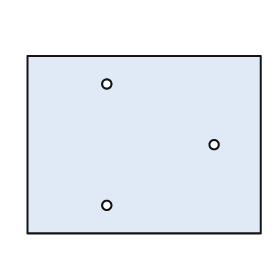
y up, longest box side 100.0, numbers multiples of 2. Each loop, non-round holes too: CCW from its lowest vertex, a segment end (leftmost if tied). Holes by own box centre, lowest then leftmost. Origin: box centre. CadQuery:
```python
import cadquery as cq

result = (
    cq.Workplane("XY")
    .moveTo(-50.0, -38.0)
    .lineTo(50.0, -38.0)
    .lineTo(50.0, 38.0)
    .lineTo(-50.0, 38.0)
    .close()
    .moveTo(-16.0, -26.0)
    .circle(2.0)
    .moveTo(30.0, 0.0)
    .circle(2.0)
    .moveTo(-16.0, 26.0)
    .circle(2.0)
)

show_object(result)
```